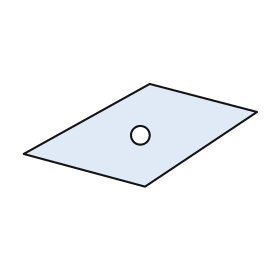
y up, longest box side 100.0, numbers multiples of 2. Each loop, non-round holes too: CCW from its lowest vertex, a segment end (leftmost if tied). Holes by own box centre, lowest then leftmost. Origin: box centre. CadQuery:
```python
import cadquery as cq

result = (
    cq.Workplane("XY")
    .moveTo(2.0, -22.0)
    .lineTo(50.0, 10.0)
    .lineTo(4.0, 22.0)
    .lineTo(-50.0, -8.0)
    .close()
    .moveTo(0.0, 0.0)
    .circle(4.0)
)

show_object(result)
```